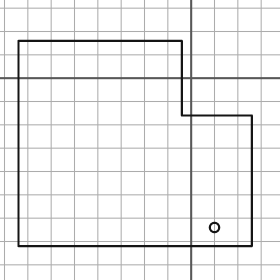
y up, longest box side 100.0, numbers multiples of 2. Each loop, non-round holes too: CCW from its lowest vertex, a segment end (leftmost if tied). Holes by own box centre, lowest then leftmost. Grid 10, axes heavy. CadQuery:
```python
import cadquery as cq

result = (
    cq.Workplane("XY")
    .moveTo(-74.0, -72.0)
    .lineTo(26.0, -72.0)
    .lineTo(26.0, -16.0)
    .lineTo(-4.0, -16.0)
    .lineTo(-4.0, 16.0)
    .lineTo(-74.0, 16.0)
    .close()
    .moveTo(10.0, -64.0)
    .circle(2.0)
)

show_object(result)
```